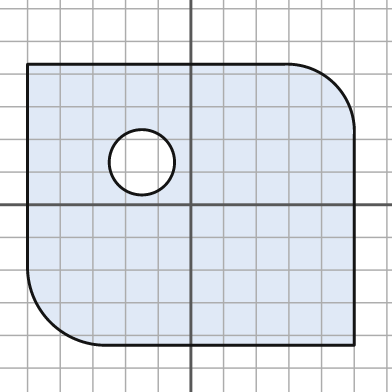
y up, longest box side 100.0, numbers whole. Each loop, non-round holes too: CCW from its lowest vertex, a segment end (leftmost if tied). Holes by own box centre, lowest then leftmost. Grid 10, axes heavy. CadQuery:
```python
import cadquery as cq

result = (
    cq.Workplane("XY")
    .moveTo(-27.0, -43.0)
    .lineTo(50.0, -43.0)
    .lineTo(50.0, 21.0)
    .threePointArc((44.0, 37.0), (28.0, 43.0))
    .lineTo(-50.0, 43.0)
    .lineTo(-50.0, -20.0)
    .threePointArc((-43.0, -36.0), (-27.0, -43.0))
    .close()
    .moveTo(-15.0, 13.0)
    .circle(10.0)
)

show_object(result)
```